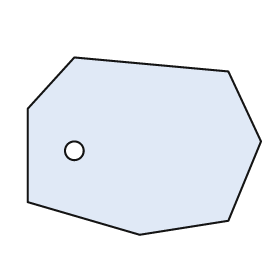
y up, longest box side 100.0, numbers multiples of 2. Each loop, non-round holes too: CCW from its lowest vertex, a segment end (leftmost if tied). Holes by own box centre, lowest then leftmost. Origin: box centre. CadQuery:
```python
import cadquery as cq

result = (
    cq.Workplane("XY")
    .moveTo(-2.0, -38.0)
    .lineTo(36.0, -32.0)
    .lineTo(50.0, 2.0)
    .lineTo(36.0, 32.0)
    .lineTo(-30.0, 38.0)
    .lineTo(-50.0, 16.0)
    .lineTo(-50.0, -24.0)
    .close()
    .moveTo(-30.0, -2.0)
    .circle(4.0)
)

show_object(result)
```